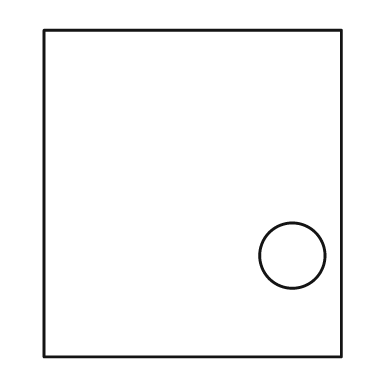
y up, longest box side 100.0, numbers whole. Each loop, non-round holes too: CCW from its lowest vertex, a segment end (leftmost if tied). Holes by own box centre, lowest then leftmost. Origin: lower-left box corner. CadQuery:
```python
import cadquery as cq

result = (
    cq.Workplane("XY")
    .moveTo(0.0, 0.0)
    .lineTo(91.0, 0.0)
    .lineTo(91.0, 100.0)
    .lineTo(0.0, 100.0)
    .close()
    .moveTo(76.0, 31.0)
    .circle(10.0)
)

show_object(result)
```